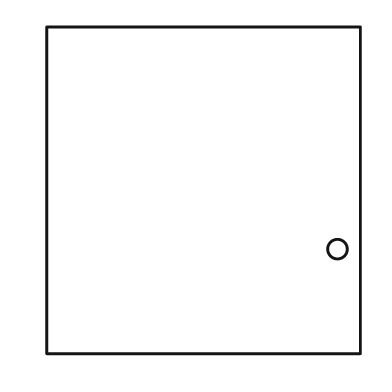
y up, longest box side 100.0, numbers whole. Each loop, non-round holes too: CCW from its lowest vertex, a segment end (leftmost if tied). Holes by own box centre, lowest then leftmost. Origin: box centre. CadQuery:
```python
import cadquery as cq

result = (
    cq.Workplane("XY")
    .moveTo(-48.0, -50.0)
    .lineTo(48.0, -50.0)
    .lineTo(48.0, 50.0)
    .lineTo(-48.0, 50.0)
    .close()
    .moveTo(41.0, -18.0)
    .circle(3.0)
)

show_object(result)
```